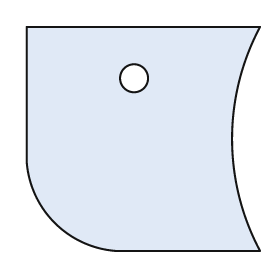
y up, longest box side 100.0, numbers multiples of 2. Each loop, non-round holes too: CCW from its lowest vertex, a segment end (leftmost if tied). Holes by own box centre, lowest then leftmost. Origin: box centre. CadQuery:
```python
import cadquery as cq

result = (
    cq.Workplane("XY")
    .moveTo(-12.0, -48.0)
    .lineTo(50.0, -48.0)
    .threePointArc((38.0, 0.0), (50.0, 48.0))
    .lineTo(-50.0, 48.0)
    .lineTo(-50.0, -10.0)
    .threePointArc((-38.0, -36.0), (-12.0, -48.0))
    .close()
    .moveTo(-4.0, 26.0)
    .circle(6.0)
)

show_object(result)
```